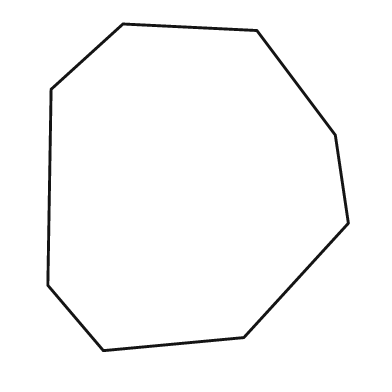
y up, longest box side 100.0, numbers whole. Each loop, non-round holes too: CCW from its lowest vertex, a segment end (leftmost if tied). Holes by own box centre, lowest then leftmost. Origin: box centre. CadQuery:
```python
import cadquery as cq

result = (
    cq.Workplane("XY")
    .moveTo(-29.0, -50.0)
    .lineTo(14.0, -46.0)
    .lineTo(46.0, -11.0)
    .lineTo(42.0, 16.0)
    .lineTo(18.0, 48.0)
    .lineTo(-23.0, 50.0)
    .lineTo(-45.0, 30.0)
    .lineTo(-46.0, -30.0)
    .close()
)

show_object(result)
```